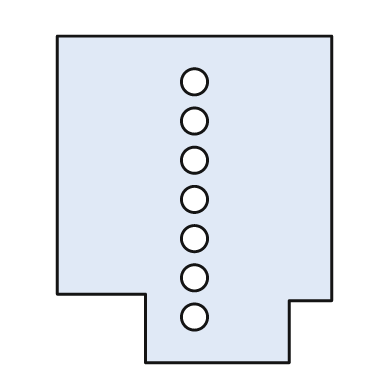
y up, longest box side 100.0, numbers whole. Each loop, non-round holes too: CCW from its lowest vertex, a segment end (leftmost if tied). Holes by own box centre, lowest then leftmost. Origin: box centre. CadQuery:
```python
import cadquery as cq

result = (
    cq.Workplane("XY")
    .moveTo(-15.0, -50.0)
    .lineTo(29.0, -50.0)
    .lineTo(29.0, -31.0)
    .lineTo(42.0, -31.0)
    .lineTo(42.0, 50.0)
    .lineTo(-42.0, 50.0)
    .lineTo(-42.0, -29.0)
    .lineTo(-15.0, -29.0)
    .close()
    .moveTo(0.0, -36.0)
    .circle(4.0)
    .moveTo(0.0, -24.0)
    .circle(4.0)
    .moveTo(0.0, -12.0)
    .circle(4.0)
    .moveTo(0.0, 0.0)
    .circle(4.0)
    .moveTo(0.0, 12.0)
    .circle(4.0)
    .moveTo(0.0, 24.0)
    .circle(4.0)
    .moveTo(0.0, 36.0)
    .circle(4.0)
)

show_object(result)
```